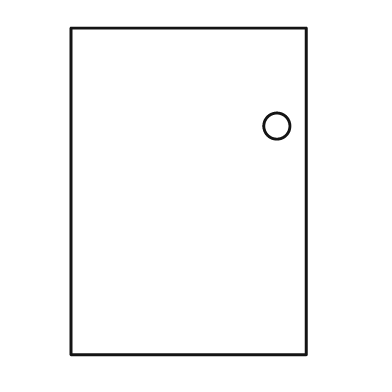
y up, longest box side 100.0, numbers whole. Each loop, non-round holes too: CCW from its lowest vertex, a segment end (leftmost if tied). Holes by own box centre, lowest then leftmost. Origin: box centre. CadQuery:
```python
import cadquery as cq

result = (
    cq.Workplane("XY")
    .moveTo(-36.0, -50.0)
    .lineTo(36.0, -50.0)
    .lineTo(36.0, 50.0)
    .lineTo(-36.0, 50.0)
    .close()
    .moveTo(27.0, 20.0)
    .circle(4.0)
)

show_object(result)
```